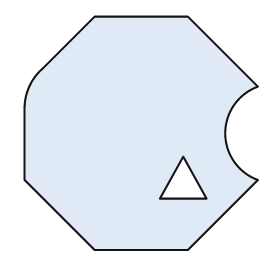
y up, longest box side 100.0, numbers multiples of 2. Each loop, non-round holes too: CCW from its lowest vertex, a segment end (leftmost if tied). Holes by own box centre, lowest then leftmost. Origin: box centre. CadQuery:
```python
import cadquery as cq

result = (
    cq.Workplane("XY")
    .moveTo(-20.0, -50.0)
    .lineTo(20.0, -50.0)
    .lineTo(50.0, -20.0)
    .threePointArc((36.0, 0.0), (50.0, 20.0))
    .lineTo(20.0, 50.0)
    .lineTo(-20.0, 50.0)
    .lineTo(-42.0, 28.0)
    .threePointArc((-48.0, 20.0), (-50.0, 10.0))
    .lineTo(-50.0, -20.0)
    .close()
    .moveTo(8.0, -28.0)
    .lineTo(28.0, -28.0)
    .lineTo(18.0, -10.0)
    .close()
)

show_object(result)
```